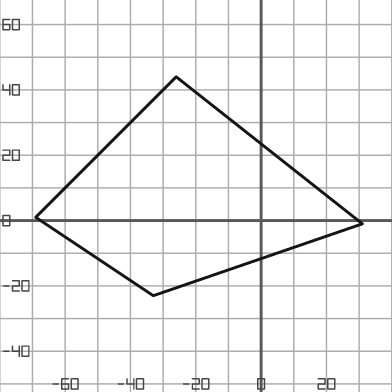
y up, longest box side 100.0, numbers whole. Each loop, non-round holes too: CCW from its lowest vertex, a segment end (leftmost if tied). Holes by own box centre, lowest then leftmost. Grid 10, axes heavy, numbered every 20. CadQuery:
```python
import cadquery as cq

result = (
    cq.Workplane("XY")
    .moveTo(-33.0, -23.0)
    .lineTo(31.0, -1.0)
    .lineTo(-26.0, 44.0)
    .lineTo(-69.0, 1.0)
    .close()
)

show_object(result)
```